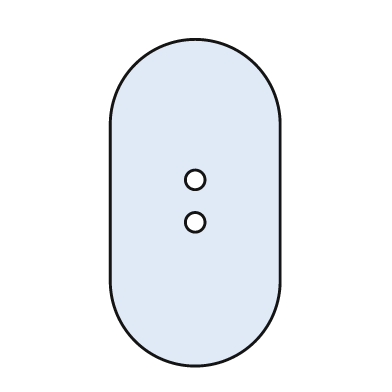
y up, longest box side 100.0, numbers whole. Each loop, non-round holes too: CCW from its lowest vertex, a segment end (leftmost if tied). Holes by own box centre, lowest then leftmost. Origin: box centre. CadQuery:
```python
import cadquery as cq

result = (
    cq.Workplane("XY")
    .moveTo(-26.0, -24.0)
    .threePointArc((0.0, -50.0), (26.0, -24.0))
    .lineTo(26.0, 24.0)
    .threePointArc((0.0, 50.0), (-26.0, 24.0))
    .close()
    .moveTo(0.0, -6.0)
    .circle(3.0)
    .moveTo(0.0, 7.0)
    .circle(3.0)
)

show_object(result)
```